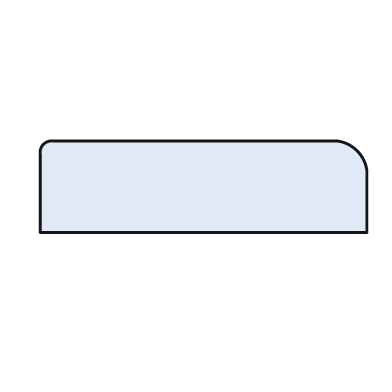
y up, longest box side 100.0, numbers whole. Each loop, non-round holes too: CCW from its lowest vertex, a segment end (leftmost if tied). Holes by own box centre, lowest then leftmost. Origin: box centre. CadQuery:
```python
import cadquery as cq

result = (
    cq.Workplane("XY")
    .moveTo(-50.0, -14.0)
    .lineTo(50.0, -14.0)
    .lineTo(50.0, 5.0)
    .threePointArc((47.0, 11.0), (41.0, 14.0))
    .lineTo(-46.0, 14.0)
    .threePointArc((-49.0, 13.0), (-50.0, 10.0))
    .close()
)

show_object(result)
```